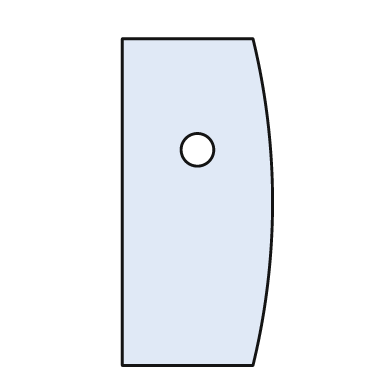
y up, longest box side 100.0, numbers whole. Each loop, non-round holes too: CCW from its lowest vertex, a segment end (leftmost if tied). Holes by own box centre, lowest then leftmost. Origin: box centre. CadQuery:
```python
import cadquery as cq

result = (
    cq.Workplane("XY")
    .moveTo(-23.0, -50.0)
    .lineTo(17.0, -50.0)
    .threePointArc((23.0, 0.0), (17.0, 50.0))
    .lineTo(-23.0, 50.0)
    .close()
    .moveTo(0.0, 16.0)
    .circle(5.0)
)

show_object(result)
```